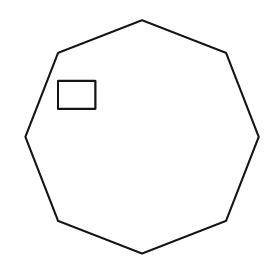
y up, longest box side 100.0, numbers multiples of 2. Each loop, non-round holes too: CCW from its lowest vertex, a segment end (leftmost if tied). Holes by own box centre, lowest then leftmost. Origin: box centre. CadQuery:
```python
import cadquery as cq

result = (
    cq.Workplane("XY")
    .moveTo(0.0, -50.0)
    .lineTo(36.0, -36.0)
    .lineTo(50.0, 0.0)
    .lineTo(36.0, 36.0)
    .lineTo(0.0, 50.0)
    .lineTo(-36.0, 36.0)
    .lineTo(-50.0, 0.0)
    .lineTo(-36.0, -36.0)
    .close()
    .moveTo(-36.0, 12.0)
    .lineTo(-20.0, 12.0)
    .lineTo(-20.0, 24.0)
    .lineTo(-36.0, 24.0)
    .close()
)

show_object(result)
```